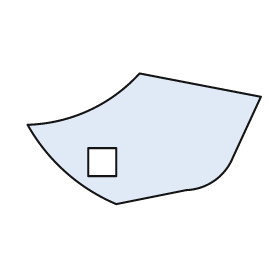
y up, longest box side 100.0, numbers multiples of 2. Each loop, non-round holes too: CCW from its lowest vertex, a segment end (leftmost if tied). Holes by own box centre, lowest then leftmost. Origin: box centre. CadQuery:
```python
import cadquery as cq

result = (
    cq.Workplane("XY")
    .moveTo(-12.0, -28.0)
    .lineTo(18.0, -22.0)
    .threePointArc((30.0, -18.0), (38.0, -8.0))
    .lineTo(50.0, 18.0)
    .lineTo(-2.0, 28.0)
    .threePointArc((-24.0, 12.0), (-50.0, 6.0))
    .threePointArc((-34.0, -14.0), (-12.0, -28.0))
    .close()
    .moveTo(-24.0, -16.0)
    .lineTo(-12.0, -16.0)
    .lineTo(-12.0, -4.0)
    .lineTo(-24.0, -4.0)
    .close()
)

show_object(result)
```